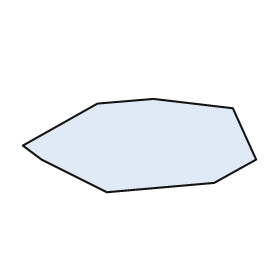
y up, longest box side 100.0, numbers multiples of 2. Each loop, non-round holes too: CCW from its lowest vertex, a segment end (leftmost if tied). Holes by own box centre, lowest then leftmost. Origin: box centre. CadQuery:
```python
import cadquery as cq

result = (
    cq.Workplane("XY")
    .moveTo(-14.0, -20.0)
    .lineTo(32.0, -16.0)
    .lineTo(50.0, -6.0)
    .lineTo(40.0, 16.0)
    .lineTo(6.0, 20.0)
    .lineTo(-18.0, 18.0)
    .lineTo(-50.0, 0.0)
    .lineTo(-42.0, -6.0)
    .close()
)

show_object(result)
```